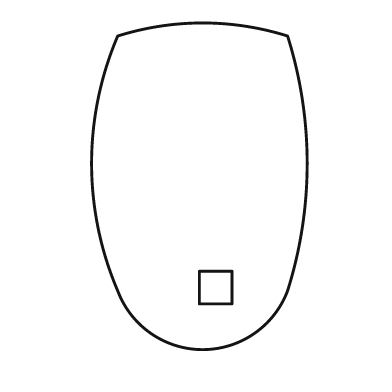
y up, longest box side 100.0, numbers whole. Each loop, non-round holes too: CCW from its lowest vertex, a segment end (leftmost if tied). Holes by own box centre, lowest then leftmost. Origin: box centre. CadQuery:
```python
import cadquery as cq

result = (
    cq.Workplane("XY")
    .moveTo(-25.0, -32.0)
    .threePointArc((1.0, -50.0), (27.0, -32.0))
    .threePointArc((33.0, 7.0), (27.0, 46.0))
    .threePointArc((1.0, 50.0), (-25.0, 46.0))
    .threePointArc((-33.0, 7.0), (-25.0, -32.0))
    .close()
    .moveTo(0.0, -36.0)
    .lineTo(10.0, -36.0)
    .lineTo(10.0, -26.0)
    .lineTo(0.0, -26.0)
    .close()
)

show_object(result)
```